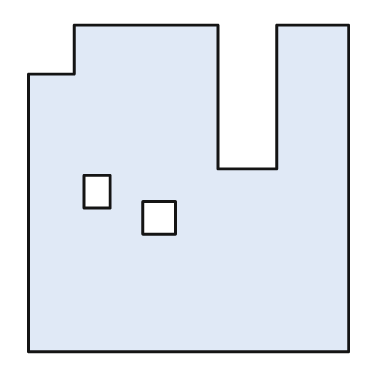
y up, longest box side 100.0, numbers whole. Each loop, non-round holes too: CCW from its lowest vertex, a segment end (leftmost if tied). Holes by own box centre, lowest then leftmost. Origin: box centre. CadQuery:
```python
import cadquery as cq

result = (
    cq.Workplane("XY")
    .moveTo(-49.0, -50.0)
    .lineTo(49.0, -50.0)
    .lineTo(49.0, 50.0)
    .lineTo(27.0, 50.0)
    .lineTo(27.0, 6.0)
    .lineTo(9.0, 6.0)
    .lineTo(9.0, 50.0)
    .lineTo(-35.0, 50.0)
    .lineTo(-35.0, 35.0)
    .lineTo(-49.0, 35.0)
    .close()
    .moveTo(-14.0, -14.0)
    .lineTo(-4.0, -14.0)
    .lineTo(-4.0, -4.0)
    .lineTo(-14.0, -4.0)
    .close()
    .moveTo(-32.0, -6.0)
    .lineTo(-24.0, -6.0)
    .lineTo(-24.0, 4.0)
    .lineTo(-32.0, 4.0)
    .close()
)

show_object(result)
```